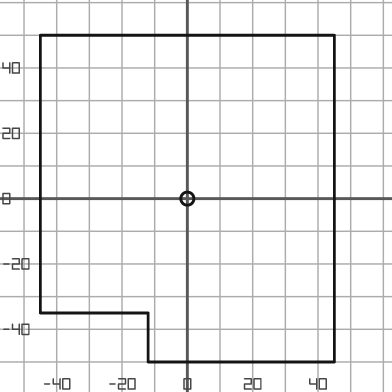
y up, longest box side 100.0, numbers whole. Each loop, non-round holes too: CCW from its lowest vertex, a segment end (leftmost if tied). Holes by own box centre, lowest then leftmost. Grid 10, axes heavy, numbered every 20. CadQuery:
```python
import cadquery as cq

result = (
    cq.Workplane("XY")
    .moveTo(-12.0, -50.0)
    .lineTo(45.0, -50.0)
    .lineTo(45.0, 50.0)
    .lineTo(-45.0, 50.0)
    .lineTo(-45.0, -35.0)
    .lineTo(-12.0, -35.0)
    .close()
    .moveTo(0.0, 0.0)
    .circle(2.0)
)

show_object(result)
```